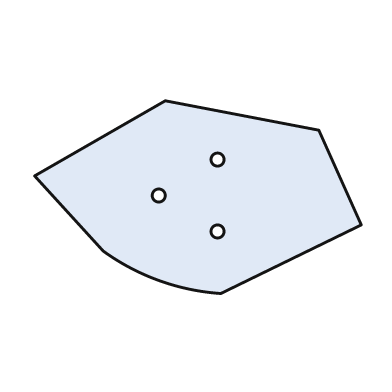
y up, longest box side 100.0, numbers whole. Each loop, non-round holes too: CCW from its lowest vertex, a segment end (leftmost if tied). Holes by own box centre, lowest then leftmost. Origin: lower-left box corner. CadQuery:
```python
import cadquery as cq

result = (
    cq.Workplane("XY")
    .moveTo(57.0, 0.0)
    .lineTo(100.0, 21.0)
    .lineTo(87.0, 50.0)
    .lineTo(40.0, 59.0)
    .lineTo(0.0, 36.0)
    .lineTo(21.0, 13.0)
    .threePointArc((38.0, 4.0), (57.0, 0.0))
    .close()
    .moveTo(56.0, 19.0)
    .circle(2.0)
    .moveTo(38.0, 30.0)
    .circle(2.0)
    .moveTo(56.0, 41.0)
    .circle(2.0)
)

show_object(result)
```